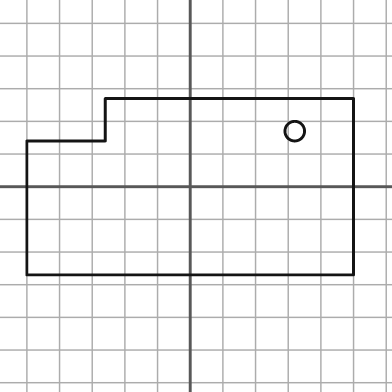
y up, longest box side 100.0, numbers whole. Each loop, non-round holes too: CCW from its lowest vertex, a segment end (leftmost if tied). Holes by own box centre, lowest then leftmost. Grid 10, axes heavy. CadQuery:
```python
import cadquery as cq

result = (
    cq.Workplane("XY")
    .moveTo(-50.0, -27.0)
    .lineTo(50.0, -27.0)
    .lineTo(50.0, 27.0)
    .lineTo(-26.0, 27.0)
    .lineTo(-26.0, 14.0)
    .lineTo(-50.0, 14.0)
    .close()
    .moveTo(32.0, 17.0)
    .circle(3.0)
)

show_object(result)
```